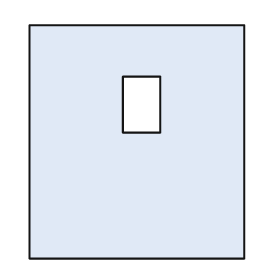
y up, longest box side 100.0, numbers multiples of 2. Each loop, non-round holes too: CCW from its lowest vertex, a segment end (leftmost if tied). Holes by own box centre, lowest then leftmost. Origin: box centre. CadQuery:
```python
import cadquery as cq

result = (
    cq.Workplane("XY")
    .moveTo(-46.0, -50.0)
    .lineTo(46.0, -50.0)
    .lineTo(46.0, 50.0)
    .lineTo(-46.0, 50.0)
    .close()
    .moveTo(-6.0, 4.0)
    .lineTo(10.0, 4.0)
    .lineTo(10.0, 28.0)
    .lineTo(-6.0, 28.0)
    .close()
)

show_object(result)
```